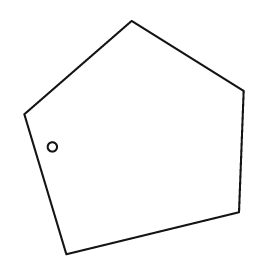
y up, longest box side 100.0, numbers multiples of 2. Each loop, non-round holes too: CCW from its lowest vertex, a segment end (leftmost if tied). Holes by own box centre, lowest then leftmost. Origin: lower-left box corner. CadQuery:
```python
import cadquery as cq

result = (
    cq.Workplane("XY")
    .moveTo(18.0, 0.0)
    .lineTo(92.0, 18.0)
    .lineTo(94.0, 70.0)
    .lineTo(46.0, 100.0)
    .lineTo(0.0, 60.0)
    .close()
    .moveTo(12.0, 46.0)
    .circle(2.0)
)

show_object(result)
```